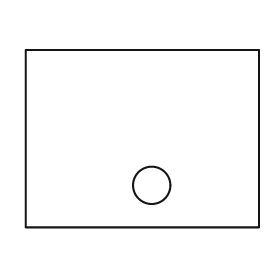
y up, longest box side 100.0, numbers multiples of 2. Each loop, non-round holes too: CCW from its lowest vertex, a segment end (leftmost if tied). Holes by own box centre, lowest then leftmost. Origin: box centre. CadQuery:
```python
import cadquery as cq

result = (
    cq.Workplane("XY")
    .moveTo(-50.0, -38.0)
    .lineTo(50.0, -38.0)
    .lineTo(50.0, 38.0)
    .lineTo(-50.0, 38.0)
    .close()
    .moveTo(4.0, -20.0)
    .circle(8.0)
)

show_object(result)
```